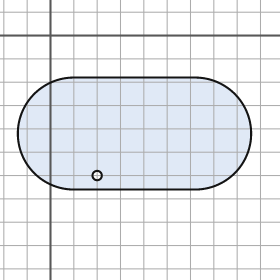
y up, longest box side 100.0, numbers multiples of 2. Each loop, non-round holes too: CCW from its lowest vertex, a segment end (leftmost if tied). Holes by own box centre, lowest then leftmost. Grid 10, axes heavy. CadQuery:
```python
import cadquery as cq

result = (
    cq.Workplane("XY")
    .moveTo(10.0, -66.0)
    .lineTo(62.0, -66.0)
    .threePointArc((86.0, -42.0), (62.0, -18.0))
    .lineTo(10.0, -18.0)
    .threePointArc((-14.0, -42.0), (10.0, -66.0))
    .close()
    .moveTo(20.0, -60.0)
    .circle(2.0)
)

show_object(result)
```